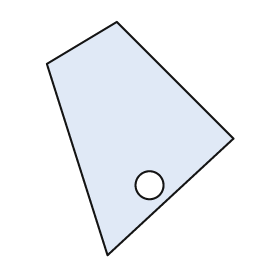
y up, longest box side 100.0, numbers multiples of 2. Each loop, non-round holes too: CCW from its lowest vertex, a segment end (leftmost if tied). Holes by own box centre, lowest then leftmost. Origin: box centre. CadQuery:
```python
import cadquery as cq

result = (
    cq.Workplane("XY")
    .moveTo(-14.0, -50.0)
    .lineTo(40.0, 0.0)
    .lineTo(-10.0, 50.0)
    .lineTo(-40.0, 32.0)
    .close()
    .moveTo(4.0, -20.0)
    .circle(6.0)
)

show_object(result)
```